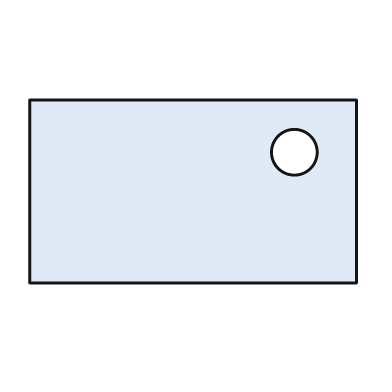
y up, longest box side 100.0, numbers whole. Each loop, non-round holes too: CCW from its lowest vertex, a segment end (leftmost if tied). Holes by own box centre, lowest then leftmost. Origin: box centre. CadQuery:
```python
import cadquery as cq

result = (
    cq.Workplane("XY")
    .moveTo(-50.0, -28.0)
    .lineTo(50.0, -28.0)
    .lineTo(50.0, 28.0)
    .lineTo(-50.0, 28.0)
    .close()
    .moveTo(31.0, 12.0)
    .circle(7.0)
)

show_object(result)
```